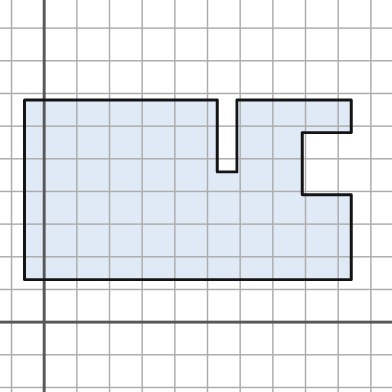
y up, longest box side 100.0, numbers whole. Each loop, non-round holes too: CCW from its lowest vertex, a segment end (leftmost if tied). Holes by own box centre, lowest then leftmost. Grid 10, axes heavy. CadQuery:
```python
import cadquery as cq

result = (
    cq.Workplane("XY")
    .moveTo(-6.0, 13.0)
    .lineTo(94.0, 13.0)
    .lineTo(94.0, 39.0)
    .lineTo(79.0, 39.0)
    .lineTo(79.0, 58.0)
    .lineTo(94.0, 58.0)
    .lineTo(94.0, 68.0)
    .lineTo(59.0, 68.0)
    .lineTo(59.0, 46.0)
    .lineTo(53.0, 46.0)
    .lineTo(53.0, 68.0)
    .lineTo(-6.0, 68.0)
    .close()
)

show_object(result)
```